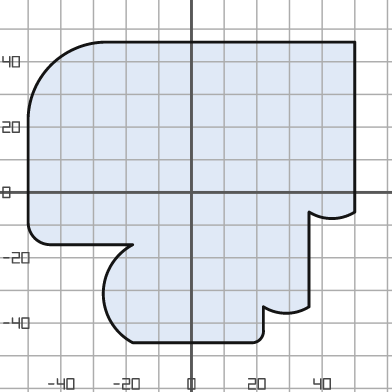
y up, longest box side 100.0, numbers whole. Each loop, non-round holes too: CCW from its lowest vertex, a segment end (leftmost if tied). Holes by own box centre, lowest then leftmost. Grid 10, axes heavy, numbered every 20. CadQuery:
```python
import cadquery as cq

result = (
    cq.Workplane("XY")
    .moveTo(-18.0, -46.0)
    .lineTo(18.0, -46.0)
    .threePointArc((21.0, -45.0), (22.0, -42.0))
    .lineTo(22.0, -35.0)
    .threePointArc((29.0, -37.0), (36.0, -35.0))
    .lineTo(36.0, -6.0)
    .threePointArc((43.0, -8.0), (50.0, -6.0))
    .lineTo(50.0, 46.0)
    .lineTo(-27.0, 46.0)
    .threePointArc((-43.0, 39.0), (-50.0, 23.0))
    .lineTo(-50.0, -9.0)
    .threePointArc((-48.0, -14.0), (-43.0, -16.0))
    .lineTo(-18.0, -16.0)
    .threePointArc((-27.0, -31.0), (-18.0, -46.0))
    .close()
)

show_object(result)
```